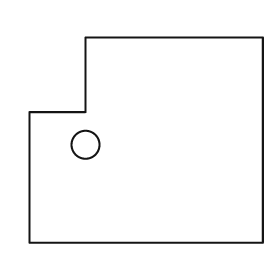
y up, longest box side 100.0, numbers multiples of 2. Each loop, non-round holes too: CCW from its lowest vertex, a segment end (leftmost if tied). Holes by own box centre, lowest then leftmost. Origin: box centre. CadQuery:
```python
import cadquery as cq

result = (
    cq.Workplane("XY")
    .moveTo(-50.0, -44.0)
    .lineTo(50.0, -44.0)
    .lineTo(50.0, 44.0)
    .lineTo(-26.0, 44.0)
    .lineTo(-26.0, 12.0)
    .lineTo(-50.0, 12.0)
    .close()
    .moveTo(-26.0, -2.0)
    .circle(6.0)
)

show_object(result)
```